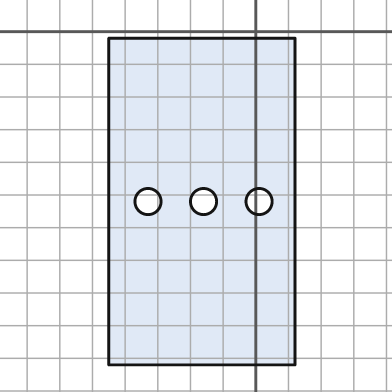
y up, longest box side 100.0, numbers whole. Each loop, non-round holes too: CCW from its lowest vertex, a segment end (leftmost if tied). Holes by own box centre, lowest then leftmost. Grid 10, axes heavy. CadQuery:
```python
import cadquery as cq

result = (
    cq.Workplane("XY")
    .moveTo(-45.0, -102.0)
    .lineTo(12.0, -102.0)
    .lineTo(12.0, -2.0)
    .lineTo(-45.0, -2.0)
    .close()
    .moveTo(-33.0, -52.0)
    .circle(4.0)
    .moveTo(-16.0, -52.0)
    .circle(4.0)
    .moveTo(1.0, -52.0)
    .circle(4.0)
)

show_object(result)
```